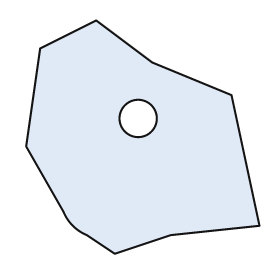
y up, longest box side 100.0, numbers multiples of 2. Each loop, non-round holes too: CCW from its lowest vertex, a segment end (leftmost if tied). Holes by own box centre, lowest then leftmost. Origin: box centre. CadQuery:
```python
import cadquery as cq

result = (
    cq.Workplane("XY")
    .moveTo(-12.0, -50.0)
    .lineTo(12.0, -42.0)
    .lineTo(50.0, -38.0)
    .lineTo(38.0, 18.0)
    .lineTo(4.0, 32.0)
    .lineTo(-20.0, 50.0)
    .lineTo(-44.0, 38.0)
    .lineTo(-50.0, -4.0)
    .lineTo(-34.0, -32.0)
    .threePointArc((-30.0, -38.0), (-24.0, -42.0))
    .close()
    .moveTo(-2.0, 8.0)
    .circle(8.0)
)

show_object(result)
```